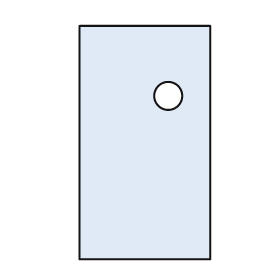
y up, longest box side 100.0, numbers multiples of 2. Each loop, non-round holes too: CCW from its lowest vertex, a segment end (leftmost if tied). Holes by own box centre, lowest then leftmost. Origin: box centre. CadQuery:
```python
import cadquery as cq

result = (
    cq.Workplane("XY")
    .moveTo(-28.0, -50.0)
    .lineTo(28.0, -50.0)
    .lineTo(28.0, 50.0)
    .lineTo(-28.0, 50.0)
    .close()
    .moveTo(10.0, 20.0)
    .circle(6.0)
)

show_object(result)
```